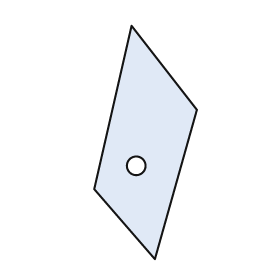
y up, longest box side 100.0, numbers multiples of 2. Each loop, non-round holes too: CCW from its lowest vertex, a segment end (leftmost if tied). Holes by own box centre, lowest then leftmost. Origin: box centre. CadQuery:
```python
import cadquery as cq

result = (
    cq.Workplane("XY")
    .moveTo(4.0, -50.0)
    .lineTo(22.0, 14.0)
    .lineTo(-6.0, 50.0)
    .lineTo(-22.0, -20.0)
    .close()
    .moveTo(-4.0, -10.0)
    .circle(4.0)
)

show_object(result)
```